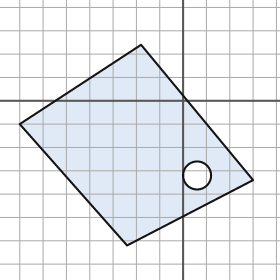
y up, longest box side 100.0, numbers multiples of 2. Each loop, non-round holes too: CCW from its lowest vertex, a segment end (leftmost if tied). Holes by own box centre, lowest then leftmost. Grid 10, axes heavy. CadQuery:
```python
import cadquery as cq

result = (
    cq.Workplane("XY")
    .moveTo(-24.0, -62.0)
    .lineTo(30.0, -34.0)
    .lineTo(-18.0, 24.0)
    .lineTo(-70.0, -10.0)
    .close()
    .moveTo(6.0, -32.0)
    .circle(6.0)
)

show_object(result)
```